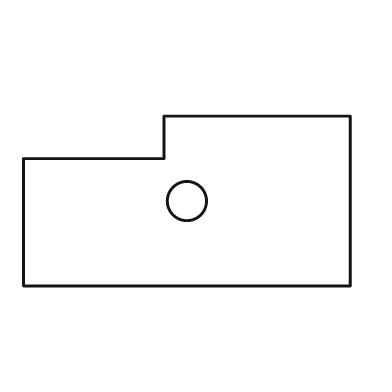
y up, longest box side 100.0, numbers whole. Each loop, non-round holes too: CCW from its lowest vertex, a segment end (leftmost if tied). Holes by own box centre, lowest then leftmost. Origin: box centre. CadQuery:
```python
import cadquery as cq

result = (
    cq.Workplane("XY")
    .moveTo(-50.0, -26.0)
    .lineTo(50.0, -26.0)
    .lineTo(50.0, 26.0)
    .lineTo(-7.0, 26.0)
    .lineTo(-7.0, 13.0)
    .lineTo(-50.0, 13.0)
    .close()
    .moveTo(0.0, 0.0)
    .circle(6.0)
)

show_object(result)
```